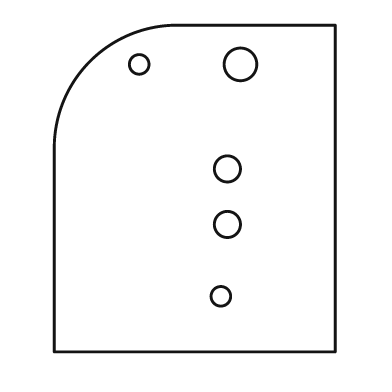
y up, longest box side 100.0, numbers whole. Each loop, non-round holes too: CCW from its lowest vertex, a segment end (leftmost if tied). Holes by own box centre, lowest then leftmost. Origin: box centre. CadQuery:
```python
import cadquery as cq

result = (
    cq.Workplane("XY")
    .moveTo(-43.0, -50.0)
    .lineTo(43.0, -50.0)
    .lineTo(43.0, 50.0)
    .lineTo(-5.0, 50.0)
    .threePointArc((-32.0, 39.0), (-43.0, 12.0))
    .close()
    .moveTo(8.0, -33.0)
    .circle(3.0)
    .moveTo(10.0, -11.0)
    .circle(4.0)
    .moveTo(10.0, 6.0)
    .circle(4.0)
    .moveTo(-17.0, 38.0)
    .circle(3.0)
    .moveTo(14.0, 38.0)
    .circle(5.0)
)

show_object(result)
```